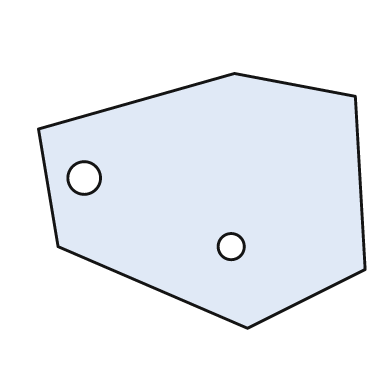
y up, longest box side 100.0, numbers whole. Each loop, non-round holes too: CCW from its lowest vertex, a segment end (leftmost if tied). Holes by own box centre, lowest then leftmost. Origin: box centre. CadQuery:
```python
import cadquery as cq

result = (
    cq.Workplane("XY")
    .moveTo(14.0, -39.0)
    .lineTo(50.0, -21.0)
    .lineTo(47.0, 32.0)
    .lineTo(10.0, 39.0)
    .lineTo(-50.0, 22.0)
    .lineTo(-44.0, -14.0)
    .close()
    .moveTo(9.0, -14.0)
    .circle(4.0)
    .moveTo(-36.0, 7.0)
    .circle(5.0)
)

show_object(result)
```